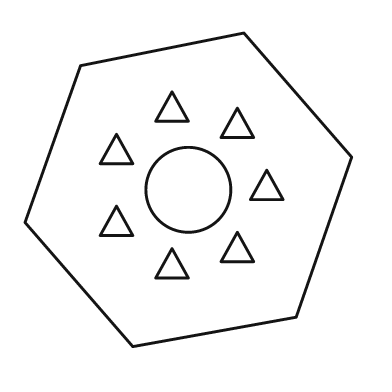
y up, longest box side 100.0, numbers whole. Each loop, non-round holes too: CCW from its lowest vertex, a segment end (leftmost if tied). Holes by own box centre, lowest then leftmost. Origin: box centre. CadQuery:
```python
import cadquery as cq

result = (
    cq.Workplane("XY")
    .moveTo(-17.0, -48.0)
    .lineTo(33.0, -39.0)
    .lineTo(50.0, 10.0)
    .lineTo(17.0, 48.0)
    .lineTo(-33.0, 38.0)
    .lineTo(-50.0, -10.0)
    .close()
    .moveTo(-10.0, -27.0)
    .lineTo(0.0, -27.0)
    .lineTo(-5.0, -18.0)
    .close()
    .moveTo(10.0, -22.0)
    .lineTo(20.0, -22.0)
    .lineTo(15.0, -13.0)
    .close()
    .moveTo(-27.0, -14.0)
    .lineTo(-17.0, -14.0)
    .lineTo(-22.0, -5.0)
    .close()
    .moveTo(0.0, 0.0)
    .circle(13.0)
    .moveTo(19.0, -3.0)
    .lineTo(29.0, -3.0)
    .lineTo(24.0, 6.0)
    .close()
    .moveTo(-27.0, 8.0)
    .lineTo(-17.0, 8.0)
    .lineTo(-22.0, 17.0)
    .close()
    .moveTo(10.0, 16.0)
    .lineTo(20.0, 16.0)
    .lineTo(15.0, 25.0)
    .close()
    .moveTo(-10.0, 21.0)
    .lineTo(0.0, 21.0)
    .lineTo(-5.0, 30.0)
    .close()
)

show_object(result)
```